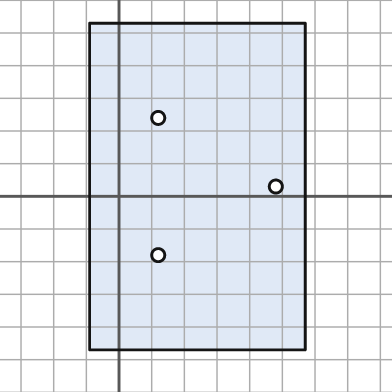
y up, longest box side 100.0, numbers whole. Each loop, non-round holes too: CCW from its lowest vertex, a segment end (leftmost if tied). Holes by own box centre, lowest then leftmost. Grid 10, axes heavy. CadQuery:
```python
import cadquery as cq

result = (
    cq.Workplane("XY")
    .moveTo(-9.0, -47.0)
    .lineTo(57.0, -47.0)
    .lineTo(57.0, 53.0)
    .lineTo(-9.0, 53.0)
    .close()
    .moveTo(12.0, -18.0)
    .circle(2.0)
    .moveTo(48.0, 3.0)
    .circle(2.0)
    .moveTo(12.0, 24.0)
    .circle(2.0)
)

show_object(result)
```